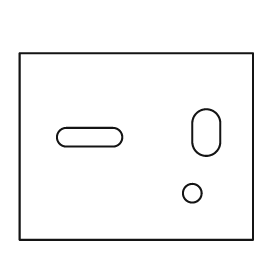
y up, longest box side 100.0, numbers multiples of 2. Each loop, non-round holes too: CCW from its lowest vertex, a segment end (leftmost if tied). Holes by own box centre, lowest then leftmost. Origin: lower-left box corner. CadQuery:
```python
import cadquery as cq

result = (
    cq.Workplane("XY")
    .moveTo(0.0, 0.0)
    .lineTo(100.0, 0.0)
    .lineTo(100.0, 80.0)
    .lineTo(0.0, 80.0)
    .close()
    .moveTo(74.0, 20.0)
    .circle(4.0)
    .moveTo(20.0, 40.0)
    .lineTo(40.0, 40.0)
    .threePointArc((44.0, 44.0), (40.0, 48.0))
    .lineTo(20.0, 48.0)
    .threePointArc((16.0, 44.0), (20.0, 40.0))
    .close()
    .moveTo(74.0, 42.0)
    .threePointArc((80.0, 36.0), (86.0, 42.0))
    .lineTo(86.0, 50.0)
    .threePointArc((80.0, 56.0), (74.0, 50.0))
    .close()
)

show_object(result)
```